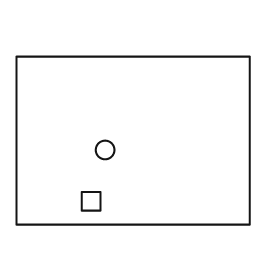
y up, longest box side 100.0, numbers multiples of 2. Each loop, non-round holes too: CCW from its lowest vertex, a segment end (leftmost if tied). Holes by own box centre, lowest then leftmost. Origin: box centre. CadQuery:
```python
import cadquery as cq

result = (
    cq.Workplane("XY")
    .moveTo(-50.0, -36.0)
    .lineTo(50.0, -36.0)
    .lineTo(50.0, 36.0)
    .lineTo(-50.0, 36.0)
    .close()
    .moveTo(-22.0, -30.0)
    .lineTo(-14.0, -30.0)
    .lineTo(-14.0, -22.0)
    .lineTo(-22.0, -22.0)
    .close()
    .moveTo(-12.0, -4.0)
    .circle(4.0)
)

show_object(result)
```